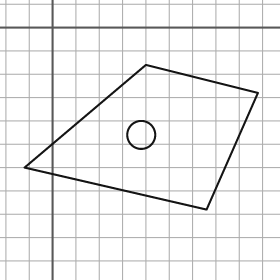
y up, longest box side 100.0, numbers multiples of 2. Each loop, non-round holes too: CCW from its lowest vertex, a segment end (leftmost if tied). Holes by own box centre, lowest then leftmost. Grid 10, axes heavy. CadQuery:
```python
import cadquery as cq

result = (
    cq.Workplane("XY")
    .moveTo(66.0, -78.0)
    .lineTo(88.0, -28.0)
    .lineTo(40.0, -16.0)
    .lineTo(-12.0, -60.0)
    .close()
    .moveTo(38.0, -46.0)
    .circle(6.0)
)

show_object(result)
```